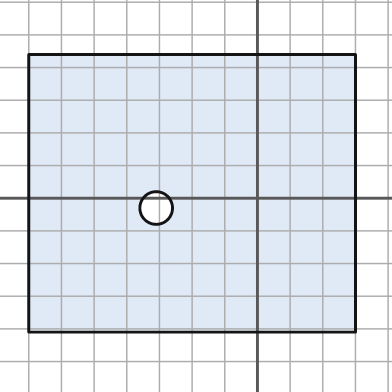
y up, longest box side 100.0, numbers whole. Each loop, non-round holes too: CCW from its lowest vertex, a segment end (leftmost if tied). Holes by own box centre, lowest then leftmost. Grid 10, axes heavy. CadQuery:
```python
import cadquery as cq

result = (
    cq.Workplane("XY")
    .moveTo(-70.0, -41.0)
    .lineTo(30.0, -41.0)
    .lineTo(30.0, 44.0)
    .lineTo(-70.0, 44.0)
    .close()
    .moveTo(-31.0, -3.0)
    .circle(5.0)
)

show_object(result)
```